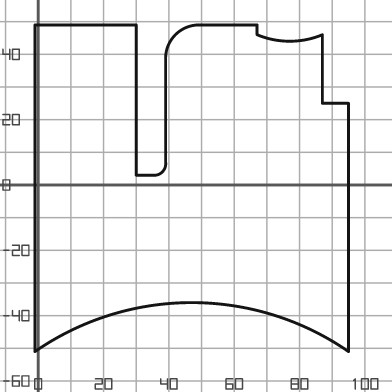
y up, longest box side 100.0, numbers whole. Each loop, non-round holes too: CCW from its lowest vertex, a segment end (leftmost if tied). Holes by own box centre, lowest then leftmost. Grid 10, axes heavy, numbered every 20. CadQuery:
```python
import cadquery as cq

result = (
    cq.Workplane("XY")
    .moveTo(-1.0, -51.0)
    .threePointArc((47.0, -36.0), (95.0, -51.0))
    .lineTo(95.0, 25.0)
    .lineTo(87.0, 25.0)
    .lineTo(87.0, 46.0)
    .threePointArc((77.0, 44.0), (67.0, 46.0))
    .lineTo(67.0, 49.0)
    .lineTo(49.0, 49.0)
    .threePointArc((42.0, 46.0), (39.0, 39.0))
    .lineTo(39.0, 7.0)
    .threePointArc((38.0, 4.0), (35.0, 3.0))
    .lineTo(30.0, 3.0)
    .lineTo(30.0, 49.0)
    .lineTo(-1.0, 49.0)
    .close()
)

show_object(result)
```